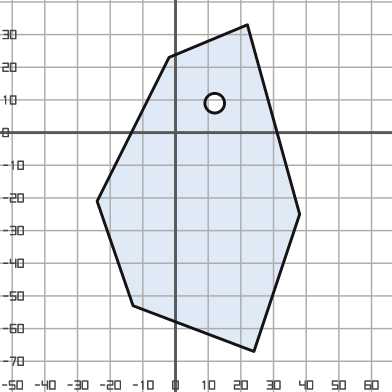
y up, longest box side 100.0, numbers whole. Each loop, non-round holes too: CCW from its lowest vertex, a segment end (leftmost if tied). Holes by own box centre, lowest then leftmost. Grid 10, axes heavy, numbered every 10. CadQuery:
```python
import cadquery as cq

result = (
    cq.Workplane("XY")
    .moveTo(24.0, -67.0)
    .lineTo(38.0, -25.0)
    .lineTo(22.0, 33.0)
    .lineTo(-2.0, 23.0)
    .lineTo(-24.0, -21.0)
    .lineTo(-13.0, -53.0)
    .close()
    .moveTo(12.0, 9.0)
    .circle(3.0)
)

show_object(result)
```